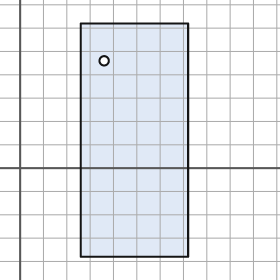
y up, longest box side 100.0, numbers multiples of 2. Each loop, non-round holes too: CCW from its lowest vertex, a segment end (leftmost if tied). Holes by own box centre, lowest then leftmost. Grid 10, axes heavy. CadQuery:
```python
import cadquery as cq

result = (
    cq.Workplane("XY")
    .moveTo(26.0, -38.0)
    .lineTo(72.0, -38.0)
    .lineTo(72.0, 62.0)
    .lineTo(26.0, 62.0)
    .close()
    .moveTo(36.0, 46.0)
    .circle(2.0)
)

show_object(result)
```